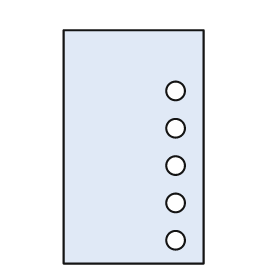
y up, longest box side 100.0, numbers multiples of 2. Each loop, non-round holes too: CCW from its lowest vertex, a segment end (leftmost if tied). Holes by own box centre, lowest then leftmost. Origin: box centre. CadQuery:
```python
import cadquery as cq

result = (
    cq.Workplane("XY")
    .moveTo(-30.0, -50.0)
    .lineTo(30.0, -50.0)
    .lineTo(30.0, 50.0)
    .lineTo(-30.0, 50.0)
    .close()
    .moveTo(18.0, -40.0)
    .circle(4.0)
    .moveTo(18.0, -24.0)
    .circle(4.0)
    .moveTo(18.0, -8.0)
    .circle(4.0)
    .moveTo(18.0, 8.0)
    .circle(4.0)
    .moveTo(18.0, 24.0)
    .circle(4.0)
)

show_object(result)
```